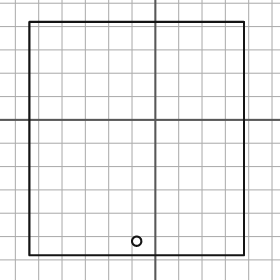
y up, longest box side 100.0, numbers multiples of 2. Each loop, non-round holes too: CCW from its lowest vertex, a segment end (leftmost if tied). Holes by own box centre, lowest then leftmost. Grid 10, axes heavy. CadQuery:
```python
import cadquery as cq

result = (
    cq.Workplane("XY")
    .moveTo(-54.0, -58.0)
    .lineTo(38.0, -58.0)
    .lineTo(38.0, 42.0)
    .lineTo(-54.0, 42.0)
    .close()
    .moveTo(-8.0, -52.0)
    .circle(2.0)
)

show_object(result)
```